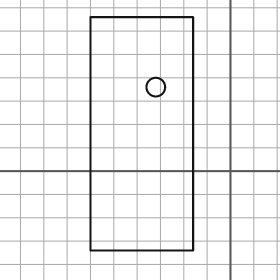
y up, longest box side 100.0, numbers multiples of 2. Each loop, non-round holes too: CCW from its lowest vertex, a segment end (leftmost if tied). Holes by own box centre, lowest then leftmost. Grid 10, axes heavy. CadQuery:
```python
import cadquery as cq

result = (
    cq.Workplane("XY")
    .moveTo(-60.0, -34.0)
    .lineTo(-16.0, -34.0)
    .lineTo(-16.0, 66.0)
    .lineTo(-60.0, 66.0)
    .close()
    .moveTo(-32.0, 36.0)
    .circle(4.0)
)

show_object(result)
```